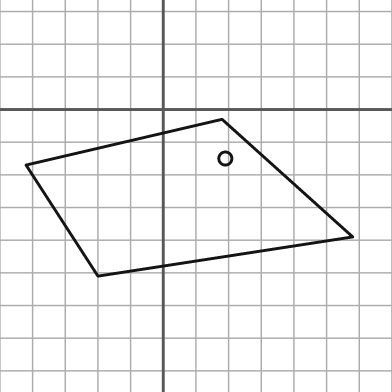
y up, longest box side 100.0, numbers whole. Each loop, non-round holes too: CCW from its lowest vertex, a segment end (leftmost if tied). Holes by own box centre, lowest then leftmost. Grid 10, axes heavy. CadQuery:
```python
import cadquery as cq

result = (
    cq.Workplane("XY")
    .moveTo(-20.0, -51.0)
    .lineTo(58.0, -39.0)
    .lineTo(18.0, -3.0)
    .lineTo(-42.0, -17.0)
    .close()
    .moveTo(19.0, -15.0)
    .circle(2.0)
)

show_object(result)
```